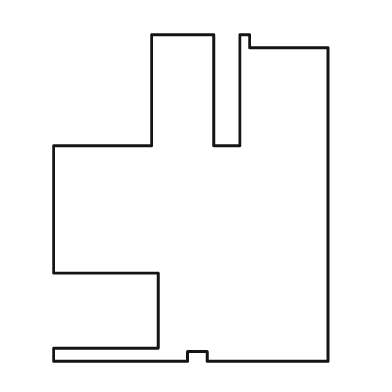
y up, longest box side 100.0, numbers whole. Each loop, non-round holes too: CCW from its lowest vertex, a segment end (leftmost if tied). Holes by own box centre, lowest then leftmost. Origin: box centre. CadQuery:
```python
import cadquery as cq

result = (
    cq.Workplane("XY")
    .moveTo(-42.0, -50.0)
    .lineTo(-1.0, -50.0)
    .lineTo(-1.0, -47.0)
    .lineTo(5.0, -47.0)
    .lineTo(5.0, -50.0)
    .lineTo(42.0, -50.0)
    .lineTo(42.0, 46.0)
    .lineTo(18.0, 46.0)
    .lineTo(18.0, 50.0)
    .lineTo(15.0, 50.0)
    .lineTo(15.0, 16.0)
    .lineTo(7.0, 16.0)
    .lineTo(7.0, 50.0)
    .lineTo(-12.0, 50.0)
    .lineTo(-12.0, 16.0)
    .lineTo(-42.0, 16.0)
    .lineTo(-42.0, -23.0)
    .lineTo(-10.0, -23.0)
    .lineTo(-10.0, -46.0)
    .lineTo(-42.0, -46.0)
    .close()
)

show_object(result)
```